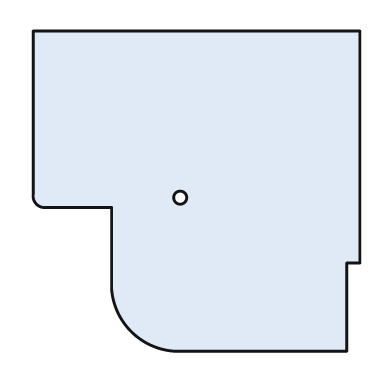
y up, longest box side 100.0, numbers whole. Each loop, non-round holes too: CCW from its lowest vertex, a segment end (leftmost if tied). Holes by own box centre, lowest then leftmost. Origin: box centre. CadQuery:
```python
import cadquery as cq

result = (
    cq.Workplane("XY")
    .moveTo(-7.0, -49.0)
    .lineTo(46.0, -49.0)
    .lineTo(46.0, -22.0)
    .lineTo(50.0, -22.0)
    .lineTo(50.0, 49.0)
    .lineTo(-50.0, 49.0)
    .lineTo(-50.0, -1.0)
    .threePointArc((-49.0, -4.0), (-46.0, -5.0))
    .lineTo(-26.0, -5.0)
    .lineTo(-26.0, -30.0)
    .threePointArc((-20.0, -43.0), (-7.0, -49.0))
    .close()
    .moveTo(-5.0, -2.0)
    .circle(2.0)
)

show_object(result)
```